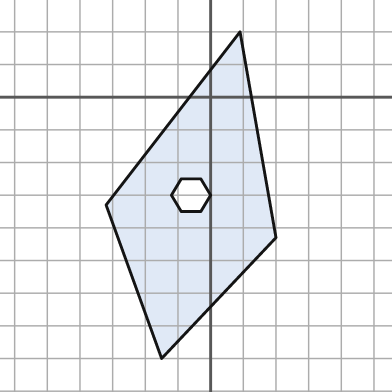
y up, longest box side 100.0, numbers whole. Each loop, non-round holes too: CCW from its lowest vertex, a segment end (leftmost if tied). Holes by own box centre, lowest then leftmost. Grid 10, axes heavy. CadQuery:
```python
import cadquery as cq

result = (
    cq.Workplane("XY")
    .moveTo(-15.0, -80.0)
    .lineTo(20.0, -43.0)
    .lineTo(9.0, 20.0)
    .lineTo(-32.0, -33.0)
    .close()
    .moveTo(-9.0, -35.0)
    .lineTo(-3.0, -35.0)
    .lineTo(0.0, -30.0)
    .lineTo(-3.0, -25.0)
    .lineTo(-9.0, -25.0)
    .lineTo(-12.0, -30.0)
    .close()
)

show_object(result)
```